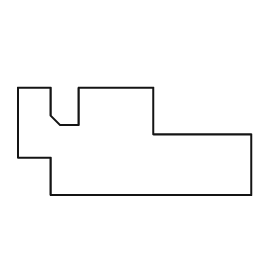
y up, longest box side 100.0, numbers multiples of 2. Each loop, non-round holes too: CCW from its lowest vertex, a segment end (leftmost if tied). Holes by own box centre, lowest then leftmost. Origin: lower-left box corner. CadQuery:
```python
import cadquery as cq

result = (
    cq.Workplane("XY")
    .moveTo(14.0, 0.0)
    .lineTo(100.0, 0.0)
    .lineTo(100.0, 26.0)
    .lineTo(58.0, 26.0)
    .lineTo(58.0, 46.0)
    .lineTo(26.0, 46.0)
    .lineTo(26.0, 30.0)
    .lineTo(18.0, 30.0)
    .lineTo(14.0, 34.0)
    .lineTo(14.0, 46.0)
    .lineTo(0.0, 46.0)
    .lineTo(0.0, 16.0)
    .lineTo(14.0, 16.0)
    .close()
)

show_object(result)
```